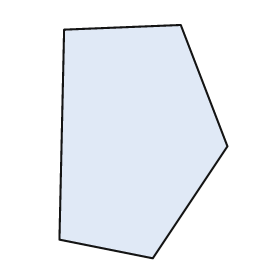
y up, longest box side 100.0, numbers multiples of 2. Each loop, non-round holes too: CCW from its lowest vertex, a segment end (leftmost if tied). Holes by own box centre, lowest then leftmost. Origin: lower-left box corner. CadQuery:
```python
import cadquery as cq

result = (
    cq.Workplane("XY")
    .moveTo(40.0, 0.0)
    .lineTo(72.0, 48.0)
    .lineTo(52.0, 100.0)
    .lineTo(2.0, 98.0)
    .lineTo(0.0, 8.0)
    .close()
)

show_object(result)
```